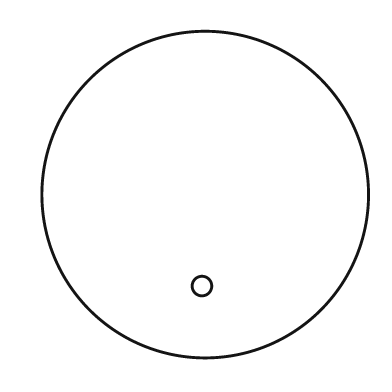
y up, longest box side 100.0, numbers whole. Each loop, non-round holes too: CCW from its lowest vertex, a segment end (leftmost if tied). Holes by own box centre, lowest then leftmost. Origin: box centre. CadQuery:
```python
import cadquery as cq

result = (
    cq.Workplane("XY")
    .moveTo(0.0, 0.0)
    .circle(50.0)
    .moveTo(-1.0, -28.0)
    .circle(3.0)
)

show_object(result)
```